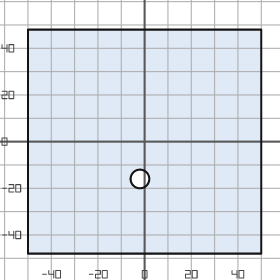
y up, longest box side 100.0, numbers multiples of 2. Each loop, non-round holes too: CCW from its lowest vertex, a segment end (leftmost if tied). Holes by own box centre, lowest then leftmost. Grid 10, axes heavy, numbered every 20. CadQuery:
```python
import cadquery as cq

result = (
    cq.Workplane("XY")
    .moveTo(-50.0, -48.0)
    .lineTo(50.0, -48.0)
    .lineTo(50.0, 48.0)
    .lineTo(-50.0, 48.0)
    .close()
    .moveTo(-2.0, -16.0)
    .circle(4.0)
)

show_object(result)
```